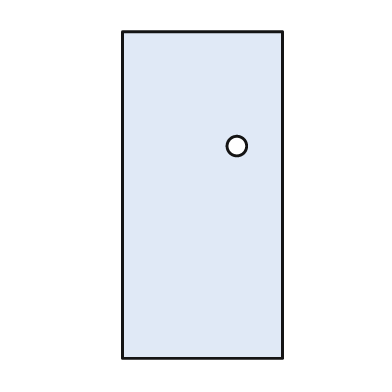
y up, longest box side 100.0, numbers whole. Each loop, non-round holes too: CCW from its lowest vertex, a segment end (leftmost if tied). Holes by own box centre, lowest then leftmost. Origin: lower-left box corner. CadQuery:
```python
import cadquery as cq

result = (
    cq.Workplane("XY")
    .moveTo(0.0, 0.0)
    .lineTo(49.0, 0.0)
    .lineTo(49.0, 100.0)
    .lineTo(0.0, 100.0)
    .close()
    .moveTo(35.0, 65.0)
    .circle(3.0)
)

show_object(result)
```